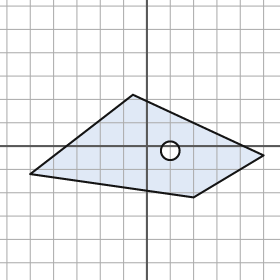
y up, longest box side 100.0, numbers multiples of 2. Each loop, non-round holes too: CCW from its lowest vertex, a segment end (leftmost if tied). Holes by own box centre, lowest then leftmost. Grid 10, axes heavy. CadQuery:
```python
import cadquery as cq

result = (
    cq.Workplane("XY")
    .moveTo(20.0, -22.0)
    .lineTo(50.0, -4.0)
    .lineTo(-6.0, 22.0)
    .lineTo(-50.0, -12.0)
    .close()
    .moveTo(10.0, -2.0)
    .circle(4.0)
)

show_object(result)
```